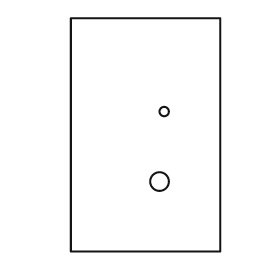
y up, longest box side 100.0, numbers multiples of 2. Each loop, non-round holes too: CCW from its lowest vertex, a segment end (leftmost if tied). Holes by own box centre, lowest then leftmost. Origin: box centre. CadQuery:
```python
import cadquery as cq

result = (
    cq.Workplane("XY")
    .moveTo(-32.0, -50.0)
    .lineTo(32.0, -50.0)
    .lineTo(32.0, 50.0)
    .lineTo(-32.0, 50.0)
    .close()
    .moveTo(6.0, -20.0)
    .circle(4.0)
    .moveTo(8.0, 10.0)
    .circle(2.0)
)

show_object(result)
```